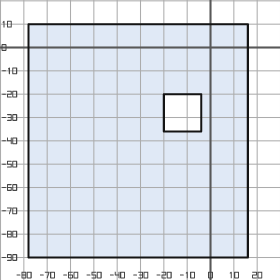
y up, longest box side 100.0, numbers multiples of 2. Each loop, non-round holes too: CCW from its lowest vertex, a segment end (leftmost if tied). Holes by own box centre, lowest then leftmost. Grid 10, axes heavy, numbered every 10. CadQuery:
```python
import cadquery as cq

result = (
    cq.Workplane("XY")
    .moveTo(-78.0, -90.0)
    .lineTo(16.0, -90.0)
    .lineTo(16.0, 10.0)
    .lineTo(-78.0, 10.0)
    .close()
    .moveTo(-20.0, -36.0)
    .lineTo(-4.0, -36.0)
    .lineTo(-4.0, -20.0)
    .lineTo(-20.0, -20.0)
    .close()
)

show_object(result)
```